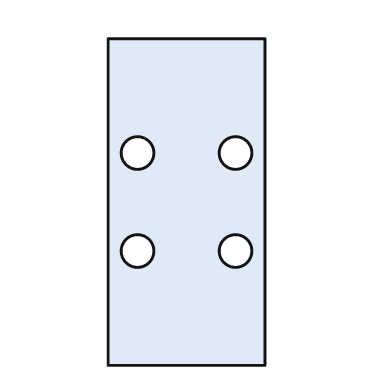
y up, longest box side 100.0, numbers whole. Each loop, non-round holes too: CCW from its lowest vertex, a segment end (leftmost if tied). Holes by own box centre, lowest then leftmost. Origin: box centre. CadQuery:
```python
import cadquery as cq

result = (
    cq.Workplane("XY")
    .moveTo(-24.0, -50.0)
    .lineTo(24.0, -50.0)
    .lineTo(24.0, 50.0)
    .lineTo(-24.0, 50.0)
    .close()
    .moveTo(-15.0, -15.0)
    .circle(5.0)
    .moveTo(15.0, -15.0)
    .circle(5.0)
    .moveTo(-15.0, 15.0)
    .circle(5.0)
    .moveTo(15.0, 15.0)
    .circle(5.0)
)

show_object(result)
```